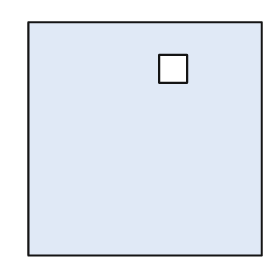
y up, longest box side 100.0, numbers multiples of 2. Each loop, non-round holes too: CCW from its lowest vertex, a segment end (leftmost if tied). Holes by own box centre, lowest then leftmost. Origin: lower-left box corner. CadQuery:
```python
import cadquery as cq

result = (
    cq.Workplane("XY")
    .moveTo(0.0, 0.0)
    .lineTo(100.0, 0.0)
    .lineTo(100.0, 100.0)
    .lineTo(0.0, 100.0)
    .close()
    .moveTo(56.0, 74.0)
    .lineTo(68.0, 74.0)
    .lineTo(68.0, 86.0)
    .lineTo(56.0, 86.0)
    .close()
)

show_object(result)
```